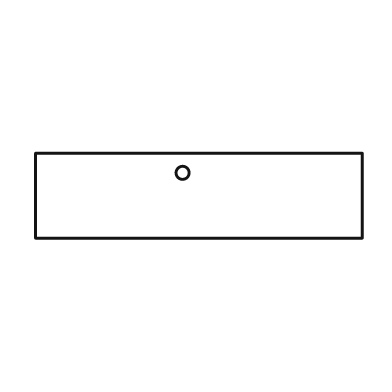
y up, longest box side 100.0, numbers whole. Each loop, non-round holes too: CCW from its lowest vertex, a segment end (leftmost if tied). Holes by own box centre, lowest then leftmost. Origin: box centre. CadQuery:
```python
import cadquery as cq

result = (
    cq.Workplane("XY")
    .moveTo(-50.0, -13.0)
    .lineTo(50.0, -13.0)
    .lineTo(50.0, 13.0)
    .lineTo(-50.0, 13.0)
    .close()
    .moveTo(-5.0, 7.0)
    .circle(2.0)
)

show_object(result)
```